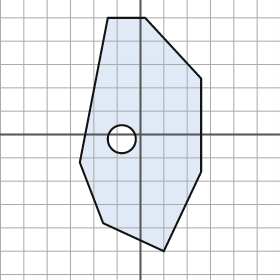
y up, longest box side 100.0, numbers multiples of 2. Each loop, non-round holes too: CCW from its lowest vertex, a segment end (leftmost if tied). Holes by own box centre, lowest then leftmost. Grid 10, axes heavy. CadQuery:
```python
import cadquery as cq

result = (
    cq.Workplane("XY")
    .moveTo(10.0, -50.0)
    .lineTo(26.0, -16.0)
    .lineTo(26.0, 24.0)
    .lineTo(2.0, 50.0)
    .lineTo(-14.0, 50.0)
    .lineTo(-26.0, -12.0)
    .lineTo(-16.0, -38.0)
    .close()
    .moveTo(-8.0, -2.0)
    .circle(6.0)
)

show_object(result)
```